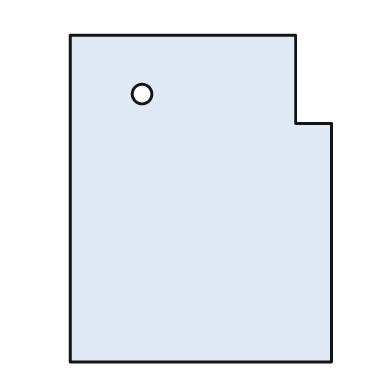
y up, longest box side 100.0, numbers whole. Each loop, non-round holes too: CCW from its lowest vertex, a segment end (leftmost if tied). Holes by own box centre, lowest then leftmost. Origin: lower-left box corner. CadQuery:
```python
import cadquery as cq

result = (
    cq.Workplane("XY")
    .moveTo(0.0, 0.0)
    .lineTo(80.0, 0.0)
    .lineTo(80.0, 73.0)
    .lineTo(69.0, 73.0)
    .lineTo(69.0, 100.0)
    .lineTo(0.0, 100.0)
    .close()
    .moveTo(22.0, 82.0)
    .circle(3.0)
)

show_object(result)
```